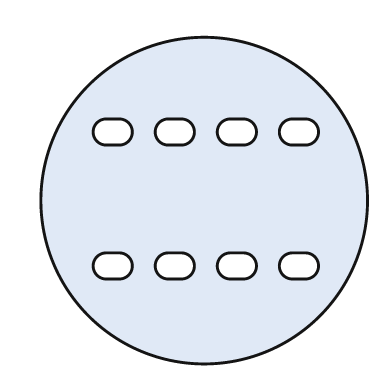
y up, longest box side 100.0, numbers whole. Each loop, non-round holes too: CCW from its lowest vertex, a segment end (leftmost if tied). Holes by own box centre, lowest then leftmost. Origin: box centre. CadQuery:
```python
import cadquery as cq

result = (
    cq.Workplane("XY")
    .moveTo(0.0, 0.0)
    .circle(50.0)
    .moveTo(-30.0, -24.0)
    .lineTo(-26.0, -24.0)
    .threePointArc((-22.0, -20.0), (-26.0, -16.0))
    .lineTo(-30.0, -16.0)
    .threePointArc((-34.0, -20.0), (-30.0, -24.0))
    .close()
    .moveTo(-11.0, -24.0)
    .lineTo(-7.0, -24.0)
    .threePointArc((-3.0, -20.0), (-7.0, -16.0))
    .lineTo(-11.0, -16.0)
    .threePointArc((-15.0, -20.0), (-11.0, -24.0))
    .close()
    .moveTo(8.0, -24.0)
    .lineTo(12.0, -24.0)
    .threePointArc((16.0, -20.0), (12.0, -16.0))
    .lineTo(8.0, -16.0)
    .threePointArc((4.0, -20.0), (8.0, -24.0))
    .close()
    .moveTo(27.0, -24.0)
    .lineTo(31.0, -24.0)
    .threePointArc((35.0, -20.0), (31.0, -16.0))
    .lineTo(27.0, -16.0)
    .threePointArc((23.0, -20.0), (27.0, -24.0))
    .close()
    .moveTo(-30.0, 17.0)
    .lineTo(-26.0, 17.0)
    .threePointArc((-22.0, 21.0), (-26.0, 25.0))
    .lineTo(-30.0, 25.0)
    .threePointArc((-34.0, 21.0), (-30.0, 17.0))
    .close()
    .moveTo(-11.0, 17.0)
    .lineTo(-7.0, 17.0)
    .threePointArc((-3.0, 21.0), (-7.0, 25.0))
    .lineTo(-11.0, 25.0)
    .threePointArc((-15.0, 21.0), (-11.0, 17.0))
    .close()
    .moveTo(8.0, 17.0)
    .lineTo(12.0, 17.0)
    .threePointArc((16.0, 21.0), (12.0, 25.0))
    .lineTo(8.0, 25.0)
    .threePointArc((4.0, 21.0), (8.0, 17.0))
    .close()
    .moveTo(27.0, 17.0)
    .lineTo(31.0, 17.0)
    .threePointArc((35.0, 21.0), (31.0, 25.0))
    .lineTo(27.0, 25.0)
    .threePointArc((23.0, 21.0), (27.0, 17.0))
    .close()
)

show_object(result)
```